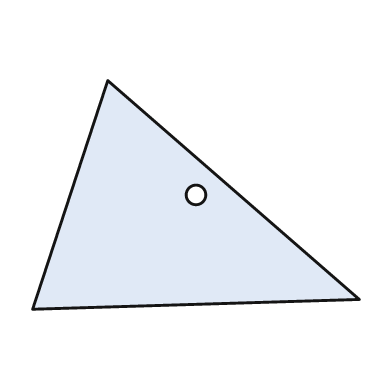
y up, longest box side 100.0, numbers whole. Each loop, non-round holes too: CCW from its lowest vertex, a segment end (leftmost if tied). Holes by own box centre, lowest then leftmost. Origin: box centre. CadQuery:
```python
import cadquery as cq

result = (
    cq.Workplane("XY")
    .moveTo(-50.0, -35.0)
    .lineTo(50.0, -32.0)
    .lineTo(-27.0, 35.0)
    .close()
    .moveTo(0.0, 0.0)
    .circle(3.0)
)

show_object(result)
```